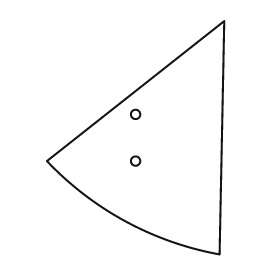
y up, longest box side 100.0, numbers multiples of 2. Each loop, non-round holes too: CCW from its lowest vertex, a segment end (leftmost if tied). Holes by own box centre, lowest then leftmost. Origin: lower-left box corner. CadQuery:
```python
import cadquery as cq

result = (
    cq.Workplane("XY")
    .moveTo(74.0, 0.0)
    .lineTo(76.0, 100.0)
    .lineTo(0.0, 40.0)
    .threePointArc((34.0, 14.0), (74.0, 0.0))
    .close()
    .moveTo(38.0, 40.0)
    .circle(2.0)
    .moveTo(38.0, 60.0)
    .circle(2.0)
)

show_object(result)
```